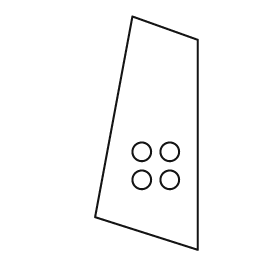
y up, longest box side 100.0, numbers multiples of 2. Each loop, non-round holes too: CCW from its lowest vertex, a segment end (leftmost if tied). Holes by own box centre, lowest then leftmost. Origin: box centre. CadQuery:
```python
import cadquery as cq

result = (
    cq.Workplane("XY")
    .moveTo(22.0, -50.0)
    .lineTo(22.0, 40.0)
    .lineTo(-6.0, 50.0)
    .lineTo(-22.0, -36.0)
    .close()
    .moveTo(-2.0, -20.0)
    .circle(4.0)
    .moveTo(10.0, -20.0)
    .circle(4.0)
    .moveTo(-2.0, -8.0)
    .circle(4.0)
    .moveTo(10.0, -8.0)
    .circle(4.0)
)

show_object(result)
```